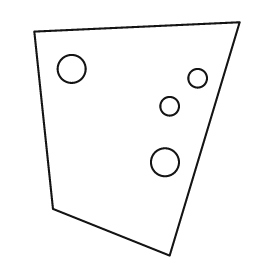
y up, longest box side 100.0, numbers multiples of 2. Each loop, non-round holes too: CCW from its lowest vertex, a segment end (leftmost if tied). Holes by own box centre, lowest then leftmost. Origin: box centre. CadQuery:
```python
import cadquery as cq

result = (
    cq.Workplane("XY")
    .moveTo(14.0, -50.0)
    .lineTo(44.0, 50.0)
    .lineTo(-44.0, 46.0)
    .lineTo(-36.0, -30.0)
    .close()
    .moveTo(12.0, -10.0)
    .circle(6.0)
    .moveTo(14.0, 14.0)
    .circle(4.0)
    .moveTo(26.0, 26.0)
    .circle(4.0)
    .moveTo(-28.0, 30.0)
    .circle(6.0)
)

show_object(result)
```